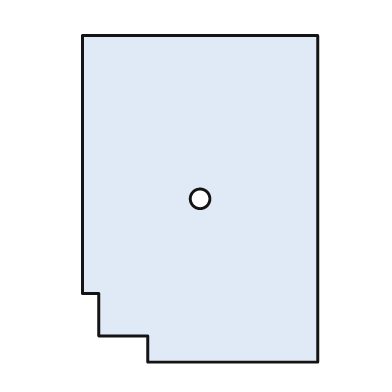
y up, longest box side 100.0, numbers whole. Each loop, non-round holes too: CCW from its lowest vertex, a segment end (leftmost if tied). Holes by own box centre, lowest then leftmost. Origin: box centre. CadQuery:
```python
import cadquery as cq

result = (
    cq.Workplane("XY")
    .moveTo(-16.0, -50.0)
    .lineTo(36.0, -50.0)
    .lineTo(36.0, 50.0)
    .lineTo(-36.0, 50.0)
    .lineTo(-36.0, -29.0)
    .lineTo(-31.0, -29.0)
    .lineTo(-31.0, -42.0)
    .lineTo(-16.0, -42.0)
    .close()
    .moveTo(0.0, 0.0)
    .circle(3.0)
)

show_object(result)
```